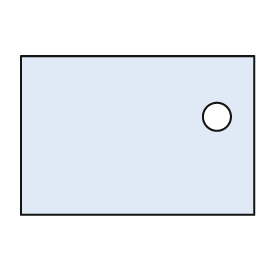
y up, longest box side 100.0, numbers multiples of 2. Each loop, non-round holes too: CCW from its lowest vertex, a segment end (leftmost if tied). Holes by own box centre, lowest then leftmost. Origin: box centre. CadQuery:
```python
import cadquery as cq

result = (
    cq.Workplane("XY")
    .moveTo(-50.0, -34.0)
    .lineTo(50.0, -34.0)
    .lineTo(50.0, 34.0)
    .lineTo(-50.0, 34.0)
    .close()
    .moveTo(34.0, 8.0)
    .circle(6.0)
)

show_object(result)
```